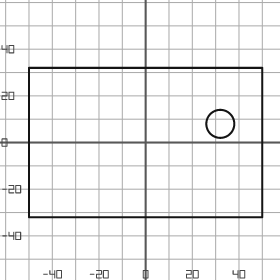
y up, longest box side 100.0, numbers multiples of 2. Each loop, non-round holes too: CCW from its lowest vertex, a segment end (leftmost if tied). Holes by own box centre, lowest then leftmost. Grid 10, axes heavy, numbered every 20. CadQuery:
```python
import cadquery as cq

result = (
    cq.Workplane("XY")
    .moveTo(-50.0, -32.0)
    .lineTo(50.0, -32.0)
    .lineTo(50.0, 32.0)
    .lineTo(-50.0, 32.0)
    .close()
    .moveTo(32.0, 8.0)
    .circle(6.0)
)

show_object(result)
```